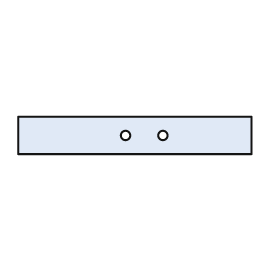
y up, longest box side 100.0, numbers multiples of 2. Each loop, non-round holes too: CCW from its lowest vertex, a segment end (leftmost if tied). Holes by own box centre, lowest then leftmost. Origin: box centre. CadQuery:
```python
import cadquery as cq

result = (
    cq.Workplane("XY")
    .moveTo(-50.0, -8.0)
    .lineTo(50.0, -8.0)
    .lineTo(50.0, 8.0)
    .lineTo(-50.0, 8.0)
    .close()
    .moveTo(-4.0, 0.0)
    .circle(2.0)
    .moveTo(12.0, 0.0)
    .circle(2.0)
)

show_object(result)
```